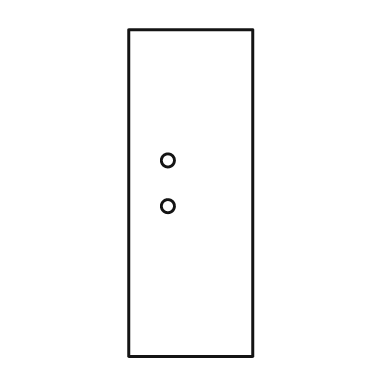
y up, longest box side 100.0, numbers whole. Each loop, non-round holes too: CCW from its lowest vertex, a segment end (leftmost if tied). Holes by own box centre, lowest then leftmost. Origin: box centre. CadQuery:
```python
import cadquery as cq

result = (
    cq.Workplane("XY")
    .moveTo(-19.0, -50.0)
    .lineTo(19.0, -50.0)
    .lineTo(19.0, 50.0)
    .lineTo(-19.0, 50.0)
    .close()
    .moveTo(-7.0, -4.0)
    .circle(2.0)
    .moveTo(-7.0, 10.0)
    .circle(2.0)
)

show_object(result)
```